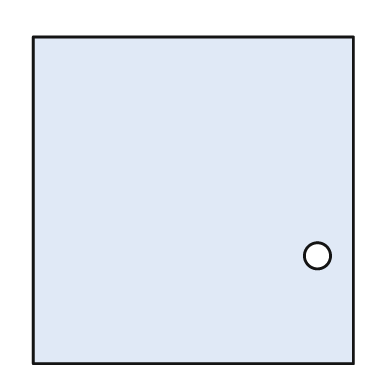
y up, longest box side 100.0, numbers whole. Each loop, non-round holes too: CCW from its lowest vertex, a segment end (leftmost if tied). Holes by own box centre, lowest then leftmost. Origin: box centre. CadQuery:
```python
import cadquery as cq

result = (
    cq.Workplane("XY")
    .moveTo(-49.0, -50.0)
    .lineTo(49.0, -50.0)
    .lineTo(49.0, 50.0)
    .lineTo(-49.0, 50.0)
    .close()
    .moveTo(38.0, -17.0)
    .circle(4.0)
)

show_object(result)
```